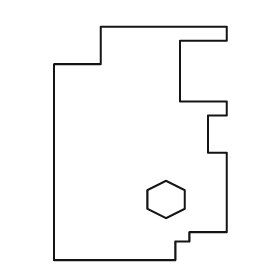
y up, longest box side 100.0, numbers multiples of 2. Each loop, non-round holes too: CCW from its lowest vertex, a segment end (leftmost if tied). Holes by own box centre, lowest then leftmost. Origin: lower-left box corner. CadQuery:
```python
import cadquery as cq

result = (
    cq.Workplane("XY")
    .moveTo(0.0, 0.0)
    .lineTo(52.0, 0.0)
    .lineTo(52.0, 8.0)
    .lineTo(58.0, 8.0)
    .lineTo(58.0, 12.0)
    .lineTo(74.0, 12.0)
    .lineTo(74.0, 46.0)
    .lineTo(66.0, 46.0)
    .lineTo(66.0, 62.0)
    .lineTo(74.0, 62.0)
    .lineTo(74.0, 68.0)
    .lineTo(54.0, 68.0)
    .lineTo(54.0, 94.0)
    .lineTo(74.0, 94.0)
    .lineTo(74.0, 100.0)
    .lineTo(20.0, 100.0)
    .lineTo(20.0, 84.0)
    .lineTo(0.0, 84.0)
    .close()
    .moveTo(48.0, 18.0)
    .lineTo(56.0, 22.0)
    .lineTo(56.0, 30.0)
    .lineTo(48.0, 34.0)
    .lineTo(40.0, 30.0)
    .lineTo(40.0, 22.0)
    .close()
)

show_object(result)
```